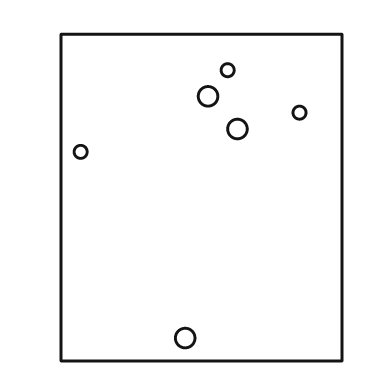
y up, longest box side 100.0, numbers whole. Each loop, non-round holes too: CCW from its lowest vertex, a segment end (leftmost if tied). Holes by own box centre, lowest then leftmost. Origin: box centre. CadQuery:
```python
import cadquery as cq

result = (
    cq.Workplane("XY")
    .moveTo(-43.0, -50.0)
    .lineTo(43.0, -50.0)
    .lineTo(43.0, 50.0)
    .lineTo(-43.0, 50.0)
    .close()
    .moveTo(-5.0, -43.0)
    .circle(3.0)
    .moveTo(-37.0, 14.0)
    .circle(2.0)
    .moveTo(11.0, 21.0)
    .circle(3.0)
    .moveTo(30.0, 26.0)
    .circle(2.0)
    .moveTo(2.0, 31.0)
    .circle(3.0)
    .moveTo(8.0, 39.0)
    .circle(2.0)
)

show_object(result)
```